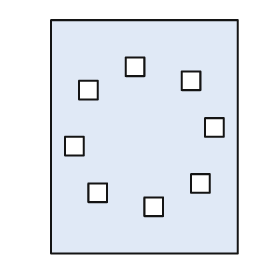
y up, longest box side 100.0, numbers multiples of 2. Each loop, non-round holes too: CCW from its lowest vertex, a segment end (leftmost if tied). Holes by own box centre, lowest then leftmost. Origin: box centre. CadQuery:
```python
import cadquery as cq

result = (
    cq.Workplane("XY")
    .moveTo(-40.0, -50.0)
    .lineTo(40.0, -50.0)
    .lineTo(40.0, 50.0)
    .lineTo(-40.0, 50.0)
    .close()
    .moveTo(0.0, -34.0)
    .lineTo(8.0, -34.0)
    .lineTo(8.0, -26.0)
    .lineTo(0.0, -26.0)
    .close()
    .moveTo(-24.0, -28.0)
    .lineTo(-16.0, -28.0)
    .lineTo(-16.0, -20.0)
    .lineTo(-24.0, -20.0)
    .close()
    .moveTo(20.0, -24.0)
    .lineTo(28.0, -24.0)
    .lineTo(28.0, -16.0)
    .lineTo(20.0, -16.0)
    .close()
    .moveTo(-34.0, -8.0)
    .lineTo(-26.0, -8.0)
    .lineTo(-26.0, 0.0)
    .lineTo(-34.0, 0.0)
    .close()
    .moveTo(26.0, 0.0)
    .lineTo(34.0, 0.0)
    .lineTo(34.0, 8.0)
    .lineTo(26.0, 8.0)
    .close()
    .moveTo(-28.0, 16.0)
    .lineTo(-20.0, 16.0)
    .lineTo(-20.0, 24.0)
    .lineTo(-28.0, 24.0)
    .close()
    .moveTo(16.0, 20.0)
    .lineTo(24.0, 20.0)
    .lineTo(24.0, 28.0)
    .lineTo(16.0, 28.0)
    .close()
    .moveTo(-8.0, 26.0)
    .lineTo(0.0, 26.0)
    .lineTo(0.0, 34.0)
    .lineTo(-8.0, 34.0)
    .close()
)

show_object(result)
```